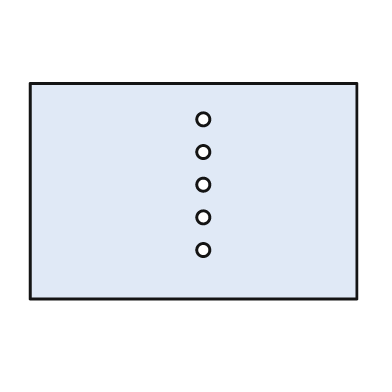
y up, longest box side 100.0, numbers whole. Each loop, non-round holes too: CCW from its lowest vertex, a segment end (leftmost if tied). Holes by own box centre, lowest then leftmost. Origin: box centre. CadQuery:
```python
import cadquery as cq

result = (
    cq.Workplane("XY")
    .moveTo(-50.0, -33.0)
    .lineTo(50.0, -33.0)
    .lineTo(50.0, 33.0)
    .lineTo(-50.0, 33.0)
    .close()
    .moveTo(3.0, -18.0)
    .circle(2.0)
    .moveTo(3.0, -8.0)
    .circle(2.0)
    .moveTo(3.0, 2.0)
    .circle(2.0)
    .moveTo(3.0, 12.0)
    .circle(2.0)
    .moveTo(3.0, 22.0)
    .circle(2.0)
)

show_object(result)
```